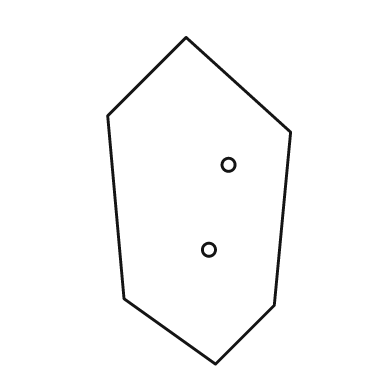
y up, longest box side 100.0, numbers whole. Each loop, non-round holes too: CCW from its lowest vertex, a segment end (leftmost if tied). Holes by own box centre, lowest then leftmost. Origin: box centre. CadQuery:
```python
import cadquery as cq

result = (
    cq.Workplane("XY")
    .moveTo(5.0, -50.0)
    .lineTo(23.0, -32.0)
    .lineTo(28.0, 21.0)
    .lineTo(-4.0, 50.0)
    .lineTo(-28.0, 26.0)
    .lineTo(-23.0, -30.0)
    .close()
    .moveTo(3.0, -15.0)
    .circle(2.0)
    .moveTo(9.0, 11.0)
    .circle(2.0)
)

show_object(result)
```